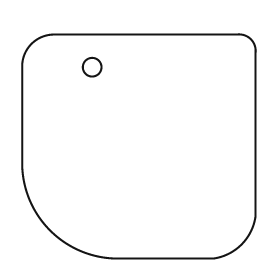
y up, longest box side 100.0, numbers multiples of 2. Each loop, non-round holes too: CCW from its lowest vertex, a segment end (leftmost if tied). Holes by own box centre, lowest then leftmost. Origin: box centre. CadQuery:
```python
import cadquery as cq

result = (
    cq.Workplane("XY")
    .moveTo(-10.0, -48.0)
    .lineTo(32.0, -48.0)
    .threePointArc((44.0, -42.0), (50.0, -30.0))
    .lineTo(50.0, 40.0)
    .threePointArc((48.0, 46.0), (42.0, 48.0))
    .lineTo(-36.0, 48.0)
    .threePointArc((-46.0, 44.0), (-50.0, 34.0))
    .lineTo(-50.0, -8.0)
    .threePointArc((-38.0, -36.0), (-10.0, -48.0))
    .close()
    .moveTo(-20.0, 34.0)
    .circle(4.0)
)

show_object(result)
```